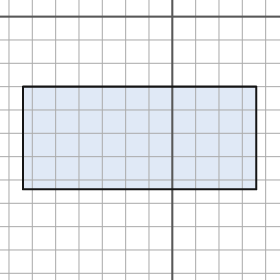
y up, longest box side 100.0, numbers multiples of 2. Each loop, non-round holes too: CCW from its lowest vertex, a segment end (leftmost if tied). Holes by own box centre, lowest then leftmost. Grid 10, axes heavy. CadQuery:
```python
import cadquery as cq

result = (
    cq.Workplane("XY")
    .moveTo(-64.0, -74.0)
    .lineTo(36.0, -74.0)
    .lineTo(36.0, -30.0)
    .lineTo(-64.0, -30.0)
    .close()
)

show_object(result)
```